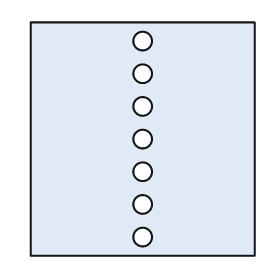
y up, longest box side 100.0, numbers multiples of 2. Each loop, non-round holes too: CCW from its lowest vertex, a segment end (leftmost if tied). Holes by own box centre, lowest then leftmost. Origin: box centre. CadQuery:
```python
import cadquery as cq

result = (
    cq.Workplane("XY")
    .moveTo(-48.0, -50.0)
    .lineTo(48.0, -50.0)
    .lineTo(48.0, 50.0)
    .lineTo(-48.0, 50.0)
    .close()
    .moveTo(0.0, -42.0)
    .circle(4.0)
    .moveTo(0.0, -28.0)
    .circle(4.0)
    .moveTo(0.0, -14.0)
    .circle(4.0)
    .moveTo(0.0, 0.0)
    .circle(4.0)
    .moveTo(0.0, 14.0)
    .circle(4.0)
    .moveTo(0.0, 28.0)
    .circle(4.0)
    .moveTo(0.0, 42.0)
    .circle(4.0)
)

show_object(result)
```